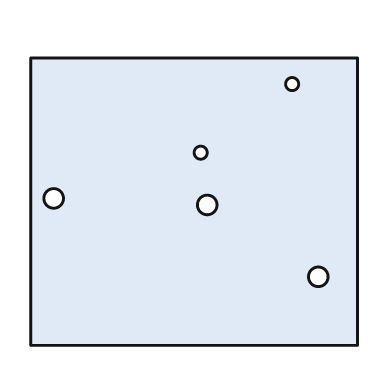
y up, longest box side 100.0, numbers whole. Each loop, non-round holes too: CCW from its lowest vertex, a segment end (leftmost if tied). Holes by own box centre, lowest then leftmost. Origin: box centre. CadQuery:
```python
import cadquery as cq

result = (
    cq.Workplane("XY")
    .moveTo(-50.0, -44.0)
    .lineTo(50.0, -44.0)
    .lineTo(50.0, 44.0)
    .lineTo(-50.0, 44.0)
    .close()
    .moveTo(38.0, -23.0)
    .circle(3.0)
    .moveTo(4.0, -1.0)
    .circle(3.0)
    .moveTo(-43.0, 1.0)
    .circle(3.0)
    .moveTo(2.0, 15.0)
    .circle(2.0)
    .moveTo(30.0, 36.0)
    .circle(2.0)
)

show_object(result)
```